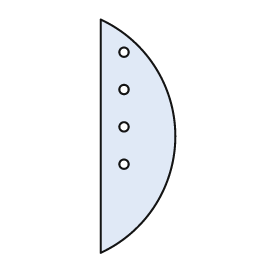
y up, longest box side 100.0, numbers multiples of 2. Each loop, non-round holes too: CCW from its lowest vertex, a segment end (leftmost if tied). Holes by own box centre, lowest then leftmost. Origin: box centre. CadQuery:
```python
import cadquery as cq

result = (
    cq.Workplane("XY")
    .moveTo(-16.0, -50.0)
    .threePointArc((16.0, 0.0), (-16.0, 50.0))
    .close()
    .moveTo(-6.0, -12.0)
    .circle(2.0)
    .moveTo(-6.0, 4.0)
    .circle(2.0)
    .moveTo(-6.0, 20.0)
    .circle(2.0)
    .moveTo(-6.0, 36.0)
    .circle(2.0)
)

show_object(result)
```